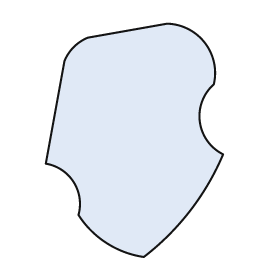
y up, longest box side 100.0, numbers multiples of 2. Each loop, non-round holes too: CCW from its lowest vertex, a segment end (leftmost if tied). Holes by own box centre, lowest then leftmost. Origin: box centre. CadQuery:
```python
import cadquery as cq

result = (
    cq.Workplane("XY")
    .moveTo(4.0, -50.0)
    .threePointArc((24.0, -30.0), (38.0, -6.0))
    .threePointArc((28.0, 8.0), (34.0, 24.0))
    .threePointArc((30.0, 42.0), (14.0, 50.0))
    .lineTo(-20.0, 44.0)
    .threePointArc((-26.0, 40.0), (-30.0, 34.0))
    .lineTo(-38.0, -10.0)
    .threePointArc((-26.0, -18.0), (-24.0, -32.0))
    .threePointArc((-12.0, -44.0), (4.0, -50.0))
    .close()
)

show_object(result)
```